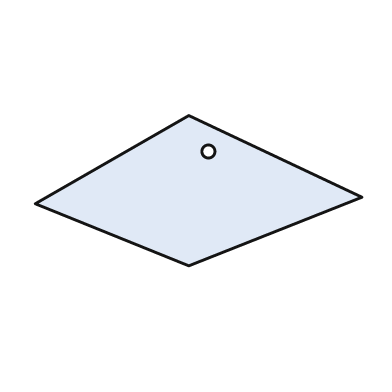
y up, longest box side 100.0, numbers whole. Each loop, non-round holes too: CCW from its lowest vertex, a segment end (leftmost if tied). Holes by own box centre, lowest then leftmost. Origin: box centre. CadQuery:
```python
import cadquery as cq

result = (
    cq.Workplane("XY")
    .moveTo(-3.0, -23.0)
    .lineTo(50.0, -2.0)
    .lineTo(-3.0, 23.0)
    .lineTo(-50.0, -4.0)
    .close()
    .moveTo(3.0, 12.0)
    .circle(2.0)
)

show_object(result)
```